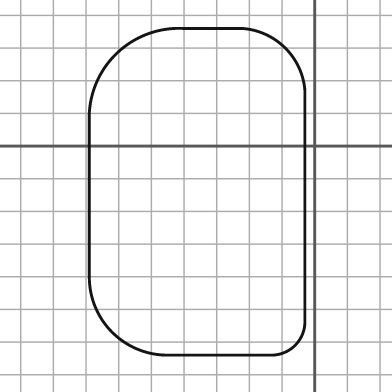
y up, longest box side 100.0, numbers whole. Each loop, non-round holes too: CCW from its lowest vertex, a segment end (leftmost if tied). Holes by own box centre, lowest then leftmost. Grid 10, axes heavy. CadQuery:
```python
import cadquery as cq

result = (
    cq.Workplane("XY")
    .moveTo(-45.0, -64.0)
    .lineTo(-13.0, -64.0)
    .threePointArc((-6.0, -61.0), (-3.0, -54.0))
    .lineTo(-3.0, 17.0)
    .threePointArc((-9.0, 30.0), (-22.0, 36.0))
    .lineTo(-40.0, 36.0)
    .threePointArc((-61.0, 28.0), (-69.0, 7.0))
    .lineTo(-69.0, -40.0)
    .threePointArc((-62.0, -57.0), (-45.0, -64.0))
    .close()
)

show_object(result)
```